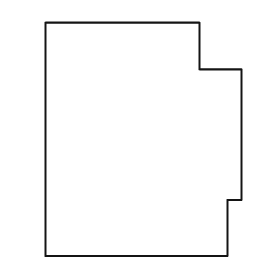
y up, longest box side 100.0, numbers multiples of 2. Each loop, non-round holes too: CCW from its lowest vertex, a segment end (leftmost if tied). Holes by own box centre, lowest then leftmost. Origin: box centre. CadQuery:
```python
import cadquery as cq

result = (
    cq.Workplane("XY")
    .moveTo(-42.0, -50.0)
    .lineTo(36.0, -50.0)
    .lineTo(36.0, -26.0)
    .lineTo(42.0, -26.0)
    .lineTo(42.0, 30.0)
    .lineTo(24.0, 30.0)
    .lineTo(24.0, 50.0)
    .lineTo(-42.0, 50.0)
    .close()
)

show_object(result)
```